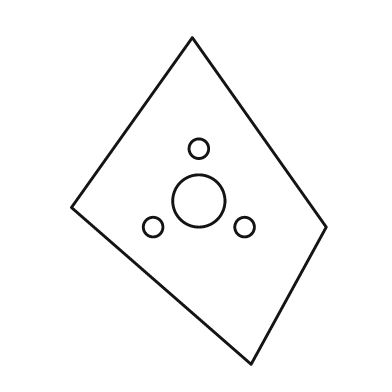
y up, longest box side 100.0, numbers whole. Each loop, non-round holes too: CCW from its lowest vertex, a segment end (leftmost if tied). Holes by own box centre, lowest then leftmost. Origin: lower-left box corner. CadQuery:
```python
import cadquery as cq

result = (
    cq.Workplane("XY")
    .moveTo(55.0, 0.0)
    .lineTo(78.0, 42.0)
    .lineTo(37.0, 100.0)
    .lineTo(0.0, 48.0)
    .close()
    .moveTo(25.0, 42.0)
    .circle(3.0)
    .moveTo(53.0, 42.0)
    .circle(3.0)
    .moveTo(39.0, 50.0)
    .circle(8.0)
    .moveTo(39.0, 66.0)
    .circle(3.0)
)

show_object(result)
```